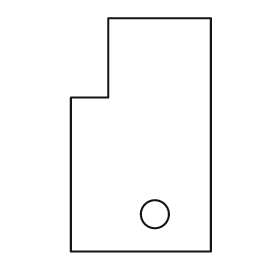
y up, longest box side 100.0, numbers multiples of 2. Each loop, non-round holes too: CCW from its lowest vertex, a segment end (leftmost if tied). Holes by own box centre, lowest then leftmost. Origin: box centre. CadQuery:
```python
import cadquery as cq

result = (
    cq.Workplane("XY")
    .moveTo(-30.0, -50.0)
    .lineTo(30.0, -50.0)
    .lineTo(30.0, 50.0)
    .lineTo(-14.0, 50.0)
    .lineTo(-14.0, 16.0)
    .lineTo(-30.0, 16.0)
    .close()
    .moveTo(6.0, -34.0)
    .circle(6.0)
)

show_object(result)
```